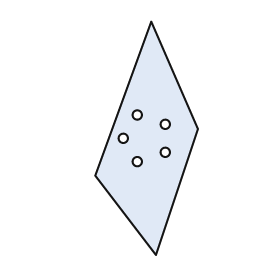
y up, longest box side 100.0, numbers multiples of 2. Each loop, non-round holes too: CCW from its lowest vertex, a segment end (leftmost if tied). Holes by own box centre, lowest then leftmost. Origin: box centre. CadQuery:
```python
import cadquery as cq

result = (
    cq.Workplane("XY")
    .moveTo(4.0, -50.0)
    .lineTo(22.0, 4.0)
    .lineTo(2.0, 50.0)
    .lineTo(-22.0, -16.0)
    .close()
    .moveTo(-4.0, -10.0)
    .circle(2.0)
    .moveTo(8.0, -6.0)
    .circle(2.0)
    .moveTo(-10.0, 0.0)
    .circle(2.0)
    .moveTo(8.0, 6.0)
    .circle(2.0)
    .moveTo(-4.0, 10.0)
    .circle(2.0)
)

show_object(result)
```